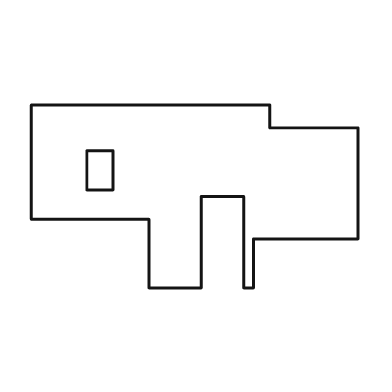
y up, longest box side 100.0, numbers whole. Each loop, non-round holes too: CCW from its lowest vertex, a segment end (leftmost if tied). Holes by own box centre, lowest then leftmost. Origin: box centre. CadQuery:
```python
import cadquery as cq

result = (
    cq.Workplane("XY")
    .moveTo(-14.0, -28.0)
    .lineTo(2.0, -28.0)
    .lineTo(2.0, 0.0)
    .lineTo(15.0, 0.0)
    .lineTo(15.0, -28.0)
    .lineTo(18.0, -28.0)
    .lineTo(18.0, -13.0)
    .lineTo(50.0, -13.0)
    .lineTo(50.0, 21.0)
    .lineTo(23.0, 21.0)
    .lineTo(23.0, 28.0)
    .lineTo(-50.0, 28.0)
    .lineTo(-50.0, -7.0)
    .lineTo(-14.0, -7.0)
    .close()
    .moveTo(-33.0, 2.0)
    .lineTo(-25.0, 2.0)
    .lineTo(-25.0, 14.0)
    .lineTo(-33.0, 14.0)
    .close()
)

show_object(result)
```